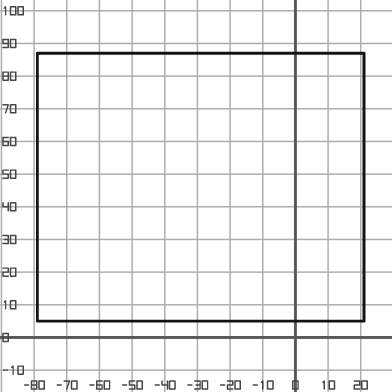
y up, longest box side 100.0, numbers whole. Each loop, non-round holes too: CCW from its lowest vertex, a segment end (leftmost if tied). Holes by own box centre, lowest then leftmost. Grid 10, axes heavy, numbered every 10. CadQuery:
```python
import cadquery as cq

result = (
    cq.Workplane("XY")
    .moveTo(-79.0, 5.0)
    .lineTo(21.0, 5.0)
    .lineTo(21.0, 87.0)
    .lineTo(-79.0, 87.0)
    .close()
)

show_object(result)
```